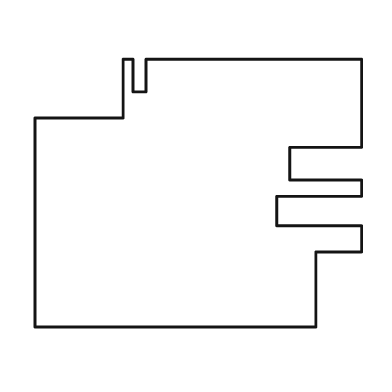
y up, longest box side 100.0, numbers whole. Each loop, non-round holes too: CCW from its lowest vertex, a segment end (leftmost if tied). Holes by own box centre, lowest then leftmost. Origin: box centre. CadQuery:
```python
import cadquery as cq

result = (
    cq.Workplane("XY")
    .moveTo(-50.0, -41.0)
    .lineTo(36.0, -41.0)
    .lineTo(36.0, -18.0)
    .lineTo(50.0, -18.0)
    .lineTo(50.0, -10.0)
    .lineTo(24.0, -10.0)
    .lineTo(24.0, -1.0)
    .lineTo(50.0, -1.0)
    .lineTo(50.0, 4.0)
    .lineTo(28.0, 4.0)
    .lineTo(28.0, 14.0)
    .lineTo(50.0, 14.0)
    .lineTo(50.0, 41.0)
    .lineTo(-16.0, 41.0)
    .lineTo(-16.0, 31.0)
    .lineTo(-20.0, 31.0)
    .lineTo(-20.0, 41.0)
    .lineTo(-23.0, 41.0)
    .lineTo(-23.0, 23.0)
    .lineTo(-50.0, 23.0)
    .close()
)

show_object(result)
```